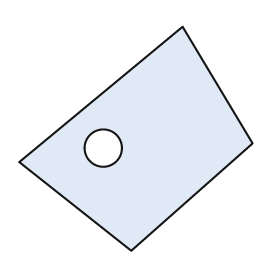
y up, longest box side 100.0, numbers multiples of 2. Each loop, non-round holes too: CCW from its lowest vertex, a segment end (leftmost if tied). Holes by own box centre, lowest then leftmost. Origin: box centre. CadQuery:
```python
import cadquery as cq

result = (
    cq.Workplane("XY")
    .moveTo(-2.0, -48.0)
    .lineTo(50.0, -2.0)
    .lineTo(20.0, 48.0)
    .lineTo(-50.0, -10.0)
    .close()
    .moveTo(-14.0, -4.0)
    .circle(8.0)
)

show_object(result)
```